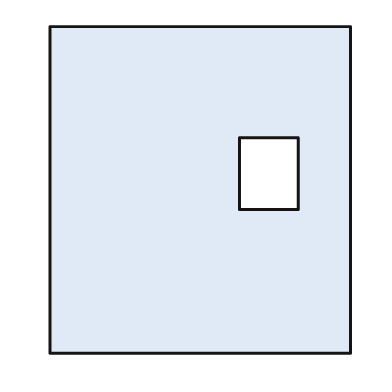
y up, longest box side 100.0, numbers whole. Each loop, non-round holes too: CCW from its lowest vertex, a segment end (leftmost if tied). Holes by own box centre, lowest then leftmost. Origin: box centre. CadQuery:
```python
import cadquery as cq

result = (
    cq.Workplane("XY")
    .moveTo(-46.0, -50.0)
    .lineTo(46.0, -50.0)
    .lineTo(46.0, 50.0)
    .lineTo(-46.0, 50.0)
    .close()
    .moveTo(12.0, -6.0)
    .lineTo(30.0, -6.0)
    .lineTo(30.0, 16.0)
    .lineTo(12.0, 16.0)
    .close()
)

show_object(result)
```